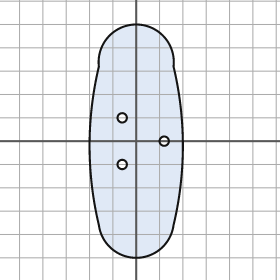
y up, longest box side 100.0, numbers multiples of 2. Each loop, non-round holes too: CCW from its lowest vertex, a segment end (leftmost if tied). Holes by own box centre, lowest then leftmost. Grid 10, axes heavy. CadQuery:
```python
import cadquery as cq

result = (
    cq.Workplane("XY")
    .moveTo(-16.0, -36.0)
    .threePointArc((0.0, -50.0), (16.0, -36.0))
    .threePointArc((20.0, -2.0), (16.0, 32.0))
    .threePointArc((0.0, 50.0), (-16.0, 32.0))
    .threePointArc((-20.0, -2.0), (-16.0, -36.0))
    .close()
    .moveTo(-6.0, -10.0)
    .circle(2.0)
    .moveTo(12.0, 0.0)
    .circle(2.0)
    .moveTo(-6.0, 10.0)
    .circle(2.0)
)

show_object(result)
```